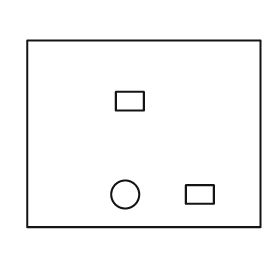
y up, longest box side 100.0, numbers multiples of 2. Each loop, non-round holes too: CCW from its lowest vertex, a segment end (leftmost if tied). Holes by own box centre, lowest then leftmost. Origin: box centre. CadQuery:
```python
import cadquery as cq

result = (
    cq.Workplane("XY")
    .moveTo(-50.0, -40.0)
    .lineTo(50.0, -40.0)
    .lineTo(50.0, 40.0)
    .lineTo(-50.0, 40.0)
    .close()
    .moveTo(-8.0, -26.0)
    .circle(6.0)
    .moveTo(18.0, -30.0)
    .lineTo(30.0, -30.0)
    .lineTo(30.0, -22.0)
    .lineTo(18.0, -22.0)
    .close()
    .moveTo(-12.0, 10.0)
    .lineTo(0.0, 10.0)
    .lineTo(0.0, 18.0)
    .lineTo(-12.0, 18.0)
    .close()
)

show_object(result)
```